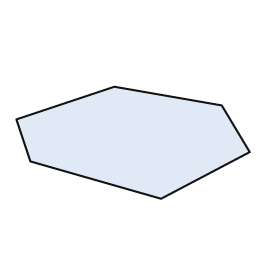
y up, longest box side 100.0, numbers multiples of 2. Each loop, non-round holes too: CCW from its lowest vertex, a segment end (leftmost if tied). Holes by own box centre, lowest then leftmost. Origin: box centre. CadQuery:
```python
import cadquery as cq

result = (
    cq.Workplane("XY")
    .moveTo(12.0, -24.0)
    .lineTo(50.0, -4.0)
    .lineTo(38.0, 16.0)
    .lineTo(-8.0, 24.0)
    .lineTo(-50.0, 10.0)
    .lineTo(-44.0, -8.0)
    .close()
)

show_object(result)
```